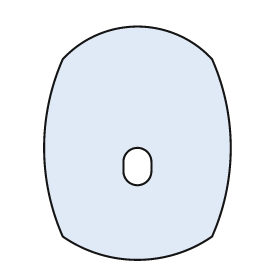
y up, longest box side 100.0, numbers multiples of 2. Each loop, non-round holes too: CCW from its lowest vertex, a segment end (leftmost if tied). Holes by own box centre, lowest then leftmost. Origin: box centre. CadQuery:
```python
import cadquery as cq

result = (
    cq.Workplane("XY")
    .moveTo(-32.0, -40.0)
    .threePointArc((0.0, -50.0), (32.0, -40.0))
    .threePointArc((40.0, -2.0), (32.0, 36.0))
    .threePointArc((0.0, 50.0), (-32.0, 36.0))
    .threePointArc((-40.0, -2.0), (-32.0, -40.0))
    .close()
    .moveTo(-6.0, -12.0)
    .threePointArc((0.0, -18.0), (6.0, -12.0))
    .lineTo(6.0, -8.0)
    .threePointArc((0.0, -2.0), (-6.0, -8.0))
    .close()
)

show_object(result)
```